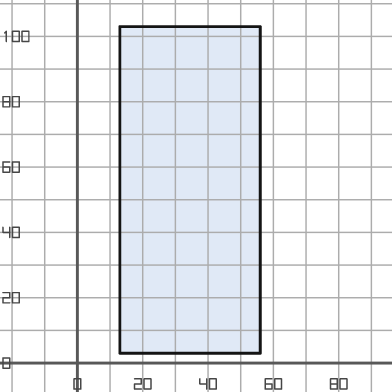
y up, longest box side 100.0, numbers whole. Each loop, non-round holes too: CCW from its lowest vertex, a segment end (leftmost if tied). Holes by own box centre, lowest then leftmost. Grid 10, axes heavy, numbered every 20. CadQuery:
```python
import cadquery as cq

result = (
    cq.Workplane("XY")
    .moveTo(13.0, 3.0)
    .lineTo(56.0, 3.0)
    .lineTo(56.0, 103.0)
    .lineTo(13.0, 103.0)
    .close()
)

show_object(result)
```